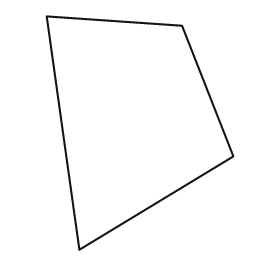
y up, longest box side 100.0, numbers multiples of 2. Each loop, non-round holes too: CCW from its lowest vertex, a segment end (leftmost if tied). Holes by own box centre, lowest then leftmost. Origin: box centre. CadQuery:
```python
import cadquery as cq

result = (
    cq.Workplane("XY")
    .moveTo(-26.0, -50.0)
    .lineTo(40.0, -10.0)
    .lineTo(18.0, 46.0)
    .lineTo(-40.0, 50.0)
    .close()
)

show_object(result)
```